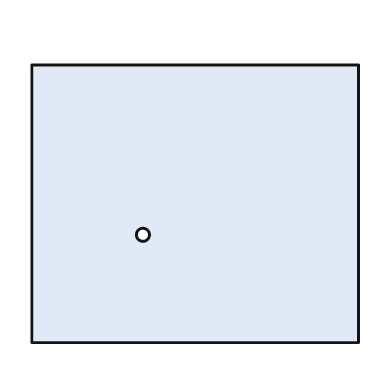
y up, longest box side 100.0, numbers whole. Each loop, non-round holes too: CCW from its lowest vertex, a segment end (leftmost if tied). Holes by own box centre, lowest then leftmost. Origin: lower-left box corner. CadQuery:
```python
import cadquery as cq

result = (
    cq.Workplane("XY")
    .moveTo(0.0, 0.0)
    .lineTo(100.0, 0.0)
    .lineTo(100.0, 85.0)
    .lineTo(0.0, 85.0)
    .close()
    .moveTo(34.0, 33.0)
    .circle(2.0)
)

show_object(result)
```